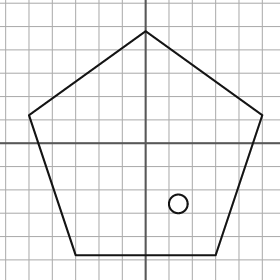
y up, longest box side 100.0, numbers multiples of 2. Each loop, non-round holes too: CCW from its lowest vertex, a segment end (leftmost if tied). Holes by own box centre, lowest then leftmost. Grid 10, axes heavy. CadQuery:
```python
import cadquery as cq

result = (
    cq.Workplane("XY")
    .moveTo(-30.0, -48.0)
    .lineTo(30.0, -48.0)
    .lineTo(50.0, 12.0)
    .lineTo(0.0, 48.0)
    .lineTo(-50.0, 12.0)
    .close()
    .moveTo(14.0, -26.0)
    .circle(4.0)
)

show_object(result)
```